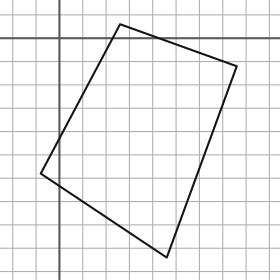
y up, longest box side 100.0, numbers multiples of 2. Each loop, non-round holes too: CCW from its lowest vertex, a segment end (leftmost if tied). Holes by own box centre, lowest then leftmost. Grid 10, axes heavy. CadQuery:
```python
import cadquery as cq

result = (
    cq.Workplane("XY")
    .moveTo(46.0, -94.0)
    .lineTo(76.0, -12.0)
    .lineTo(26.0, 6.0)
    .lineTo(-8.0, -58.0)
    .close()
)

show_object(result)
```